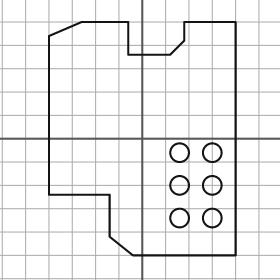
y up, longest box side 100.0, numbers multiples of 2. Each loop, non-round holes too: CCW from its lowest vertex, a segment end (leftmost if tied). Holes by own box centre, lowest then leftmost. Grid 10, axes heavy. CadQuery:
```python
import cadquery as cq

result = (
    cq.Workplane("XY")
    .moveTo(-4.0, -50.0)
    .lineTo(40.0, -50.0)
    .lineTo(40.0, 50.0)
    .lineTo(18.0, 50.0)
    .lineTo(18.0, 42.0)
    .lineTo(12.0, 36.0)
    .lineTo(-6.0, 36.0)
    .lineTo(-6.0, 50.0)
    .lineTo(-26.0, 50.0)
    .lineTo(-40.0, 44.0)
    .lineTo(-40.0, -24.0)
    .lineTo(-14.0, -24.0)
    .lineTo(-14.0, -42.0)
    .close()
    .moveTo(16.0, -34.0)
    .circle(4.0)
    .moveTo(30.0, -34.0)
    .circle(4.0)
    .moveTo(16.0, -20.0)
    .circle(4.0)
    .moveTo(30.0, -20.0)
    .circle(4.0)
    .moveTo(16.0, -6.0)
    .circle(4.0)
    .moveTo(30.0, -6.0)
    .circle(4.0)
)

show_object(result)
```